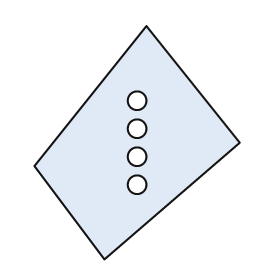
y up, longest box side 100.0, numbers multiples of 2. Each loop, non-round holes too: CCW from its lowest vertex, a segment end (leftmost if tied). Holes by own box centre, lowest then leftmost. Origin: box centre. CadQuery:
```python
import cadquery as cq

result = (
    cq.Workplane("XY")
    .moveTo(-14.0, -50.0)
    .lineTo(44.0, 0.0)
    .lineTo(4.0, 50.0)
    .lineTo(-44.0, -10.0)
    .close()
    .moveTo(0.0, -18.0)
    .circle(4.0)
    .moveTo(0.0, -6.0)
    .circle(4.0)
    .moveTo(0.0, 6.0)
    .circle(4.0)
    .moveTo(0.0, 18.0)
    .circle(4.0)
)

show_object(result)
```